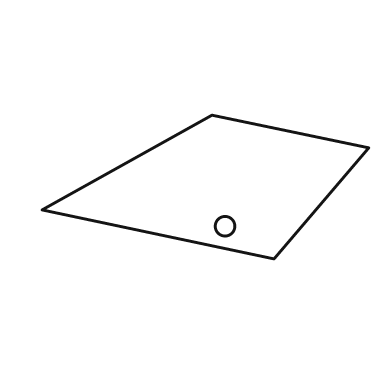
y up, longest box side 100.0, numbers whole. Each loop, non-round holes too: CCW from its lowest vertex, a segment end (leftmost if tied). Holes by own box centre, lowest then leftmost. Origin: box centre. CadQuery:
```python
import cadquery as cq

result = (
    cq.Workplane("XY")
    .moveTo(21.0, -22.0)
    .lineTo(50.0, 12.0)
    .lineTo(2.0, 22.0)
    .lineTo(-50.0, -7.0)
    .close()
    .moveTo(6.0, -12.0)
    .circle(3.0)
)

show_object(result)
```